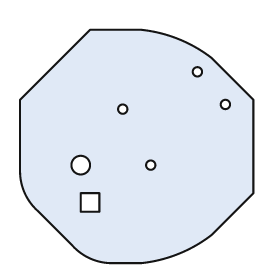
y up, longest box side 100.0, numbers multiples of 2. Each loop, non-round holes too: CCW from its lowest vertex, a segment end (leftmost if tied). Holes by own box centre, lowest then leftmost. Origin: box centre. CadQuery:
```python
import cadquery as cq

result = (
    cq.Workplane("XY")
    .moveTo(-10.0, -50.0)
    .lineTo(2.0, -50.0)
    .threePointArc((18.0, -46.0), (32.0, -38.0))
    .lineTo(50.0, -20.0)
    .lineTo(50.0, 20.0)
    .lineTo(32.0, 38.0)
    .threePointArc((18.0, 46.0), (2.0, 50.0))
    .lineTo(-20.0, 50.0)
    .lineTo(-50.0, 20.0)
    .lineTo(-50.0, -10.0)
    .threePointArc((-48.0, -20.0), (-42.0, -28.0))
    .lineTo(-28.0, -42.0)
    .threePointArc((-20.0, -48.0), (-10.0, -50.0))
    .close()
    .moveTo(-24.0, -28.0)
    .lineTo(-16.0, -28.0)
    .lineTo(-16.0, -20.0)
    .lineTo(-24.0, -20.0)
    .close()
    .moveTo(-24.0, -8.0)
    .circle(4.0)
    .moveTo(6.0, -8.0)
    .circle(2.0)
    .moveTo(-6.0, 16.0)
    .circle(2.0)
    .moveTo(38.0, 18.0)
    .circle(2.0)
    .moveTo(26.0, 32.0)
    .circle(2.0)
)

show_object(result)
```